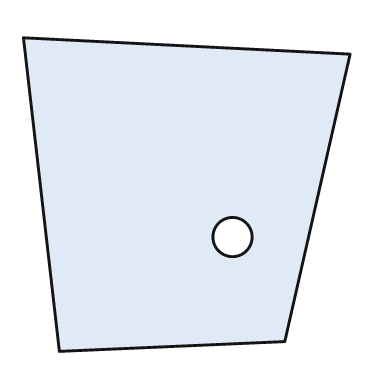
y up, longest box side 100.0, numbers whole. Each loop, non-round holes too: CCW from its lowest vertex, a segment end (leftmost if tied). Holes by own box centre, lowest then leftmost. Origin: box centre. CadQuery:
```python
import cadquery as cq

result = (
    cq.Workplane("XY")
    .moveTo(-39.0, -48.0)
    .lineTo(30.0, -45.0)
    .lineTo(50.0, 43.0)
    .lineTo(-50.0, 48.0)
    .close()
    .moveTo(14.0, -13.0)
    .circle(6.0)
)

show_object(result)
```